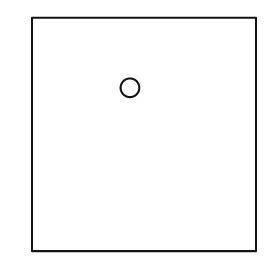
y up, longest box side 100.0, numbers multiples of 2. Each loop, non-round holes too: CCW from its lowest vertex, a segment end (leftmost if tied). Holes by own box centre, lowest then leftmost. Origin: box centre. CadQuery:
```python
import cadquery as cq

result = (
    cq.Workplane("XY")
    .moveTo(-48.0, -50.0)
    .lineTo(48.0, -50.0)
    .lineTo(48.0, 50.0)
    .lineTo(-48.0, 50.0)
    .close()
    .moveTo(-6.0, 20.0)
    .circle(4.0)
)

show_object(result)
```